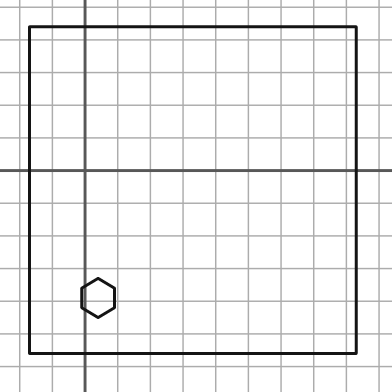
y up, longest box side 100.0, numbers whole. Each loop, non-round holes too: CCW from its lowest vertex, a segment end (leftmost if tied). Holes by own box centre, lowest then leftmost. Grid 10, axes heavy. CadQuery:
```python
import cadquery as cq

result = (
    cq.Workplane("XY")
    .moveTo(-17.0, -56.0)
    .lineTo(83.0, -56.0)
    .lineTo(83.0, 44.0)
    .lineTo(-17.0, 44.0)
    .close()
    .moveTo(4.0, -45.0)
    .lineTo(9.0, -42.0)
    .lineTo(9.0, -36.0)
    .lineTo(4.0, -33.0)
    .lineTo(-1.0, -36.0)
    .lineTo(-1.0, -42.0)
    .close()
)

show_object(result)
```